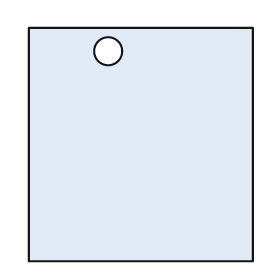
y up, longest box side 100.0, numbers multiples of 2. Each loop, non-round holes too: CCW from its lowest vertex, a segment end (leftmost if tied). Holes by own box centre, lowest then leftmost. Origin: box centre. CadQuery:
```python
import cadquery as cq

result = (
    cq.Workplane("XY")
    .moveTo(-48.0, -50.0)
    .lineTo(48.0, -50.0)
    .lineTo(48.0, 50.0)
    .lineTo(-48.0, 50.0)
    .close()
    .moveTo(-14.0, 40.0)
    .circle(6.0)
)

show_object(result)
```